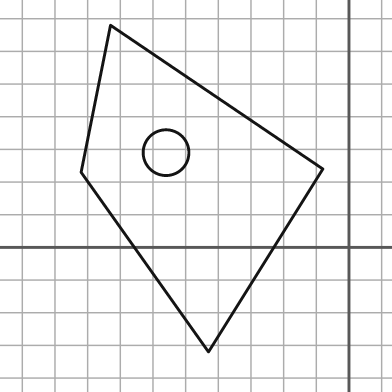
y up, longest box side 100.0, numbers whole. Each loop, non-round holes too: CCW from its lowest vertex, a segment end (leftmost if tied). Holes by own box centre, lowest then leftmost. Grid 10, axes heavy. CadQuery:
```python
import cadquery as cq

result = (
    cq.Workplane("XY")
    .moveTo(-43.0, -32.0)
    .lineTo(-8.0, 24.0)
    .lineTo(-73.0, 68.0)
    .lineTo(-82.0, 23.0)
    .close()
    .moveTo(-56.0, 29.0)
    .circle(7.0)
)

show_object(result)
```